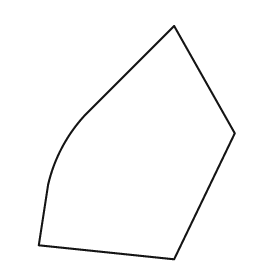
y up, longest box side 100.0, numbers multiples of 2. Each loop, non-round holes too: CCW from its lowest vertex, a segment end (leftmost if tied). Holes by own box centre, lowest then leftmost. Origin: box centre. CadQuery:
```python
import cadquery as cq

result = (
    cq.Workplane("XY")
    .moveTo(16.0, -50.0)
    .lineTo(42.0, 4.0)
    .lineTo(16.0, 50.0)
    .lineTo(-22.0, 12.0)
    .threePointArc((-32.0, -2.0), (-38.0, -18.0))
    .lineTo(-42.0, -44.0)
    .close()
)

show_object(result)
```